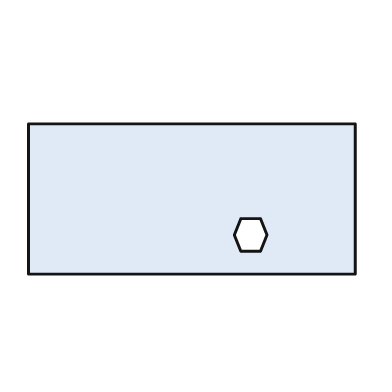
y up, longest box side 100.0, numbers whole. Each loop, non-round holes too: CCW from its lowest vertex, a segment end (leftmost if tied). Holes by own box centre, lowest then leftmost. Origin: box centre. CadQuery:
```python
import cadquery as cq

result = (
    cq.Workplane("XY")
    .moveTo(-50.0, -23.0)
    .lineTo(50.0, -23.0)
    .lineTo(50.0, 23.0)
    .lineTo(-50.0, 23.0)
    .close()
    .moveTo(15.0, -16.0)
    .lineTo(21.0, -16.0)
    .lineTo(23.0, -11.0)
    .lineTo(21.0, -6.0)
    .lineTo(15.0, -6.0)
    .lineTo(13.0, -11.0)
    .close()
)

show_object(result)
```